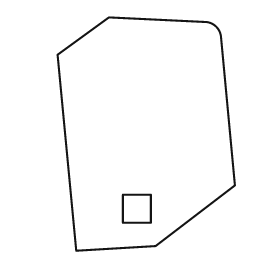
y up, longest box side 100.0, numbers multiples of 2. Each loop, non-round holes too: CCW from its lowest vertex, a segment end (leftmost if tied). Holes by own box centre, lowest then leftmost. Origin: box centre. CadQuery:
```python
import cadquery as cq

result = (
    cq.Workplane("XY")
    .moveTo(-30.0, -50.0)
    .lineTo(4.0, -48.0)
    .lineTo(38.0, -22.0)
    .lineTo(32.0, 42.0)
    .threePointArc((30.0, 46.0), (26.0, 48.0))
    .lineTo(-16.0, 50.0)
    .lineTo(-38.0, 34.0)
    .close()
    .moveTo(-10.0, -38.0)
    .lineTo(2.0, -38.0)
    .lineTo(2.0, -26.0)
    .lineTo(-10.0, -26.0)
    .close()
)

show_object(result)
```